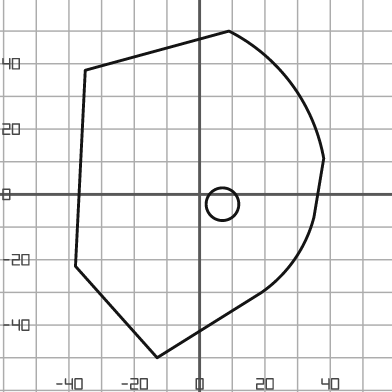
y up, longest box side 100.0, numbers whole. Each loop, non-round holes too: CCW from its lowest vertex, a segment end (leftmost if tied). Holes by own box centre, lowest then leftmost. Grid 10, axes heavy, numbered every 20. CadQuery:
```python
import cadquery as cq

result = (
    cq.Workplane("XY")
    .moveTo(-13.0, -50.0)
    .lineTo(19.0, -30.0)
    .threePointArc((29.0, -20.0), (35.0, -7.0))
    .lineTo(38.0, 11.0)
    .threePointArc((28.0, 34.0), (9.0, 50.0))
    .lineTo(-35.0, 38.0)
    .lineTo(-38.0, -22.0)
    .close()
    .moveTo(7.0, -3.0)
    .circle(5.0)
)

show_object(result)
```